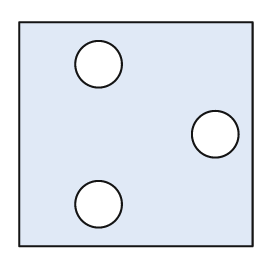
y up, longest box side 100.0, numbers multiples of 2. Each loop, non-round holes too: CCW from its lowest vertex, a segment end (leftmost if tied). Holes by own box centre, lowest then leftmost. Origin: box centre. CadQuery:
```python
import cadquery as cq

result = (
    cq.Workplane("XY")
    .moveTo(-50.0, -48.0)
    .lineTo(50.0, -48.0)
    .lineTo(50.0, 48.0)
    .lineTo(-50.0, 48.0)
    .close()
    .moveTo(-16.0, -30.0)
    .circle(10.0)
    .moveTo(34.0, 0.0)
    .circle(10.0)
    .moveTo(-16.0, 30.0)
    .circle(10.0)
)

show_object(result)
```